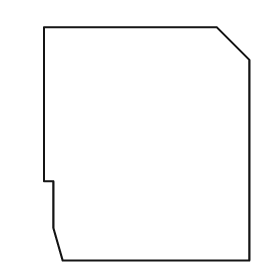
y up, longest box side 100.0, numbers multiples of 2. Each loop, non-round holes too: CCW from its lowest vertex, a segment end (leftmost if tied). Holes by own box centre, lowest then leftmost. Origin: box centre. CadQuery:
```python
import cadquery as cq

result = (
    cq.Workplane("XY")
    .moveTo(-36.0, -50.0)
    .lineTo(44.0, -50.0)
    .lineTo(44.0, 36.0)
    .lineTo(30.0, 50.0)
    .lineTo(-44.0, 50.0)
    .lineTo(-44.0, -16.0)
    .lineTo(-40.0, -16.0)
    .lineTo(-40.0, -36.0)
    .close()
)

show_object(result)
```